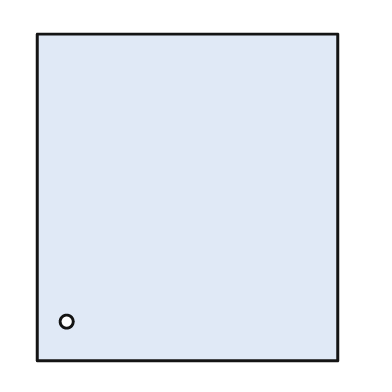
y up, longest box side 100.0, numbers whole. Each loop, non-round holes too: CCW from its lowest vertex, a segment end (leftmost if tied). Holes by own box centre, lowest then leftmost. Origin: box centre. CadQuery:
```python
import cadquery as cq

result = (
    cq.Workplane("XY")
    .moveTo(-46.0, -50.0)
    .lineTo(46.0, -50.0)
    .lineTo(46.0, 50.0)
    .lineTo(-46.0, 50.0)
    .close()
    .moveTo(-37.0, -38.0)
    .circle(2.0)
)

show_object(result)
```